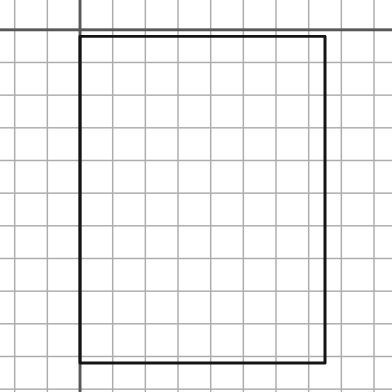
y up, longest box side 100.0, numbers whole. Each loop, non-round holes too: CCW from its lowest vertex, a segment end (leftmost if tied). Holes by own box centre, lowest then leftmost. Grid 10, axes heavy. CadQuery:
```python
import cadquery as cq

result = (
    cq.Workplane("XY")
    .moveTo(0.0, -102.0)
    .lineTo(75.0, -102.0)
    .lineTo(75.0, -2.0)
    .lineTo(0.0, -2.0)
    .close()
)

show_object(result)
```